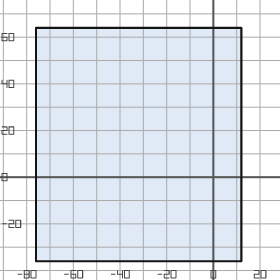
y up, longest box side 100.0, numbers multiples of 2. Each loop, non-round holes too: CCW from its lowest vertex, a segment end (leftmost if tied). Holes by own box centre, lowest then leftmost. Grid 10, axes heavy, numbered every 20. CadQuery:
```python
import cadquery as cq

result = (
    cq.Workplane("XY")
    .moveTo(-76.0, -36.0)
    .lineTo(12.0, -36.0)
    .lineTo(12.0, 64.0)
    .lineTo(-76.0, 64.0)
    .close()
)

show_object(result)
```